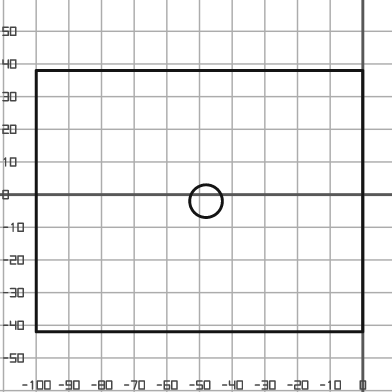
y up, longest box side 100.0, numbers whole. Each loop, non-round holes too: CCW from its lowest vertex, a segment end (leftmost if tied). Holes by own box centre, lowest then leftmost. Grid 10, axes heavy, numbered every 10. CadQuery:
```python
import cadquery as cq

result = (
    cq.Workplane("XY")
    .moveTo(-100.0, -42.0)
    .lineTo(0.0, -42.0)
    .lineTo(0.0, 38.0)
    .lineTo(-100.0, 38.0)
    .close()
    .moveTo(-48.0, -2.0)
    .circle(5.0)
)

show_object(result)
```